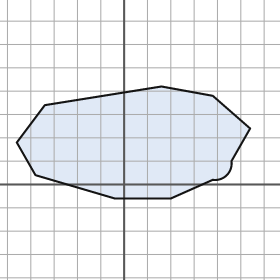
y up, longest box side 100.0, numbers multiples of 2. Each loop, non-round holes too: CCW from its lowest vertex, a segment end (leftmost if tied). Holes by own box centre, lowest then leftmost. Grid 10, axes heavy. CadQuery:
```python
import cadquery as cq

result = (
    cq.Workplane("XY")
    .moveTo(-4.0, -6.0)
    .lineTo(20.0, -6.0)
    .lineTo(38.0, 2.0)
    .threePointArc((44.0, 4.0), (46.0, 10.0))
    .lineTo(54.0, 24.0)
    .lineTo(38.0, 38.0)
    .lineTo(16.0, 42.0)
    .lineTo(-34.0, 34.0)
    .lineTo(-46.0, 18.0)
    .lineTo(-38.0, 4.0)
    .close()
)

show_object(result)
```